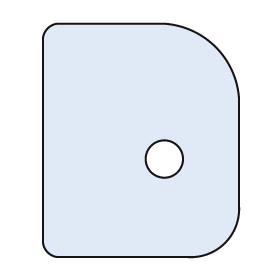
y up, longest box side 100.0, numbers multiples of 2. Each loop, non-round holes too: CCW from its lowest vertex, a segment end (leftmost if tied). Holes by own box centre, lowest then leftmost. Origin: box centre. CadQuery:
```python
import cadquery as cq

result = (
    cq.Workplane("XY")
    .moveTo(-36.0, -50.0)
    .lineTo(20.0, -50.0)
    .threePointArc((36.0, -44.0), (42.0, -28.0))
    .lineTo(42.0, 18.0)
    .threePointArc((32.0, 40.0), (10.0, 50.0))
    .lineTo(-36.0, 50.0)
    .threePointArc((-40.0, 48.0), (-42.0, 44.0))
    .lineTo(-42.0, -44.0)
    .threePointArc((-40.0, -48.0), (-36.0, -50.0))
    .close()
    .moveTo(10.0, -8.0)
    .circle(8.0)
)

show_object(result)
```